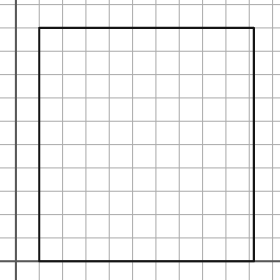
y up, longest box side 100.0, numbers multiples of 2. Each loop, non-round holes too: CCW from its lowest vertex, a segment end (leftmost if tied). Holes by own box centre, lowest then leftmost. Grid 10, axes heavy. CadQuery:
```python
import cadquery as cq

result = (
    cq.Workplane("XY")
    .moveTo(10.0, 0.0)
    .lineTo(102.0, 0.0)
    .lineTo(102.0, 100.0)
    .lineTo(10.0, 100.0)
    .close()
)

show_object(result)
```